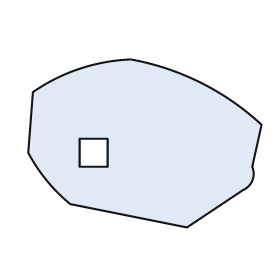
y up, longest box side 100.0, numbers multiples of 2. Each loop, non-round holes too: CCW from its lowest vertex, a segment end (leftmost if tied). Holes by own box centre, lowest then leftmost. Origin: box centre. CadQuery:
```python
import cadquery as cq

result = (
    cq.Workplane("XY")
    .moveTo(18.0, -36.0)
    .lineTo(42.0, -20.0)
    .threePointArc((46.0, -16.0), (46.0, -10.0))
    .lineTo(50.0, 8.0)
    .threePointArc((24.0, 26.0), (-6.0, 36.0))
    .threePointArc((-28.0, 32.0), (-48.0, 22.0))
    .lineTo(-50.0, -4.0)
    .threePointArc((-42.0, -16.0), (-32.0, -26.0))
    .close()
    .moveTo(-28.0, -10.0)
    .lineTo(-16.0, -10.0)
    .lineTo(-16.0, 2.0)
    .lineTo(-28.0, 2.0)
    .close()
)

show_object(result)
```